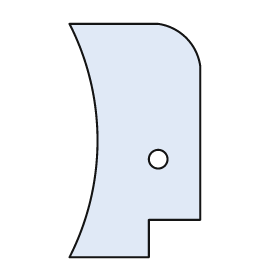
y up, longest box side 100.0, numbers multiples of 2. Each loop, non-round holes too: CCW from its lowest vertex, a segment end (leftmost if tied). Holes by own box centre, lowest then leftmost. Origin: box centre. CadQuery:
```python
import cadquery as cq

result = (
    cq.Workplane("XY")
    .moveTo(-28.0, -50.0)
    .lineTo(6.0, -50.0)
    .lineTo(6.0, -34.0)
    .lineTo(28.0, -34.0)
    .lineTo(28.0, 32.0)
    .threePointArc((22.0, 44.0), (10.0, 50.0))
    .lineTo(-28.0, 50.0)
    .threePointArc((-16.0, 0.0), (-28.0, -50.0))
    .close()
    .moveTo(10.0, -8.0)
    .circle(4.0)
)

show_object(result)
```